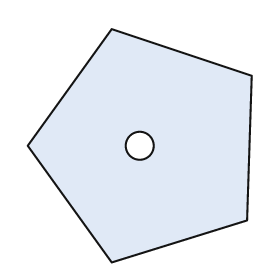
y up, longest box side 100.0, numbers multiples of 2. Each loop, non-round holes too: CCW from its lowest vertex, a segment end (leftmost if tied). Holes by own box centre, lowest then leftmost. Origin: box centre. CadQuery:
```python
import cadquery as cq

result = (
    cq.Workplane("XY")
    .moveTo(-12.0, -50.0)
    .lineTo(46.0, -32.0)
    .lineTo(48.0, 30.0)
    .lineTo(-12.0, 50.0)
    .lineTo(-48.0, 0.0)
    .close()
    .moveTo(0.0, 0.0)
    .circle(6.0)
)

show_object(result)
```